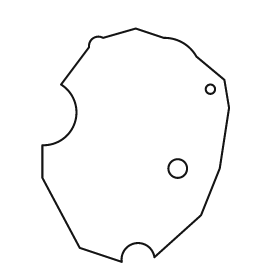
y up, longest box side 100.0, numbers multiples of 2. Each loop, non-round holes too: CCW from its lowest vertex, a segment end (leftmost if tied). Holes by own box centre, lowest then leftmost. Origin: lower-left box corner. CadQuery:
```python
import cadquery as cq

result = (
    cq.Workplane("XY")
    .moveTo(34.0, 0.0)
    .threePointArc((40.0, 8.0), (48.0, 2.0))
    .lineTo(68.0, 20.0)
    .lineTo(76.0, 40.0)
    .lineTo(80.0, 66.0)
    .lineTo(78.0, 78.0)
    .lineTo(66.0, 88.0)
    .threePointArc((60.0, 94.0), (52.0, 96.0))
    .lineTo(40.0, 100.0)
    .lineTo(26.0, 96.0)
    .threePointArc((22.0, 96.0), (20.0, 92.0))
    .lineTo(8.0, 76.0)
    .threePointArc((14.0, 60.0), (0.0, 50.0))
    .lineTo(0.0, 36.0)
    .lineTo(16.0, 6.0)
    .close()
    .moveTo(58.0, 40.0)
    .circle(4.0)
    .moveTo(72.0, 74.0)
    .circle(2.0)
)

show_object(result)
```